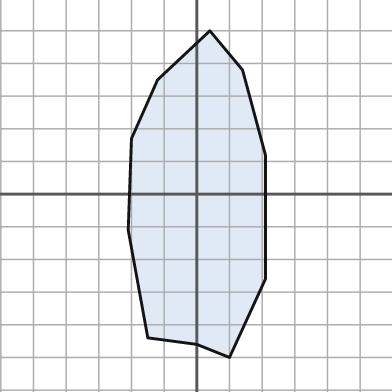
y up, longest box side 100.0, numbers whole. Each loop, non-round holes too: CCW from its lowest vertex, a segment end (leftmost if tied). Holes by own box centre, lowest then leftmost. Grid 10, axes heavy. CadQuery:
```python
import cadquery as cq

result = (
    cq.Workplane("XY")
    .moveTo(10.0, -50.0)
    .lineTo(21.0, -26.0)
    .lineTo(21.0, 12.0)
    .lineTo(14.0, 38.0)
    .lineTo(4.0, 50.0)
    .lineTo(-12.0, 35.0)
    .lineTo(-20.0, 17.0)
    .lineTo(-21.0, -11.0)
    .lineTo(-15.0, -44.0)
    .lineTo(0.0, -46.0)
    .close()
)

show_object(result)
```